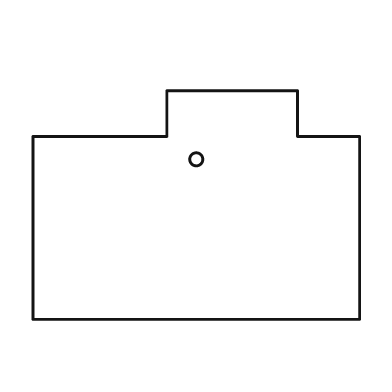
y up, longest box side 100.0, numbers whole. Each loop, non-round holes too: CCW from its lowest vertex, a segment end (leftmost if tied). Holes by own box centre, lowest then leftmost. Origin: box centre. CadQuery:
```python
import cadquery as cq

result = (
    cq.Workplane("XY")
    .moveTo(-50.0, -35.0)
    .lineTo(50.0, -35.0)
    .lineTo(50.0, 21.0)
    .lineTo(31.0, 21.0)
    .lineTo(31.0, 35.0)
    .lineTo(-9.0, 35.0)
    .lineTo(-9.0, 21.0)
    .lineTo(-50.0, 21.0)
    .close()
    .moveTo(0.0, 14.0)
    .circle(2.0)
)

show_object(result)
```